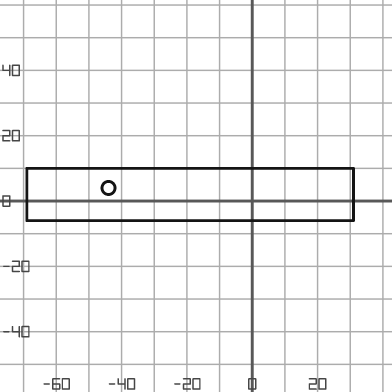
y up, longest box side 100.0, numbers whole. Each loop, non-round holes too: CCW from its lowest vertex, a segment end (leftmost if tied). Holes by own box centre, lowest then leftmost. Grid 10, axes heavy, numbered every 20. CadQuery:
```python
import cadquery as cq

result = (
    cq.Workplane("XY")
    .moveTo(-69.0, -6.0)
    .lineTo(31.0, -6.0)
    .lineTo(31.0, 10.0)
    .lineTo(-69.0, 10.0)
    .close()
    .moveTo(-44.0, 4.0)
    .circle(2.0)
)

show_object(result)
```